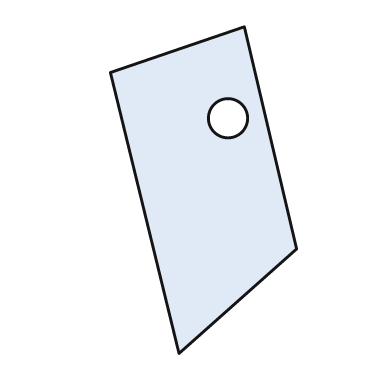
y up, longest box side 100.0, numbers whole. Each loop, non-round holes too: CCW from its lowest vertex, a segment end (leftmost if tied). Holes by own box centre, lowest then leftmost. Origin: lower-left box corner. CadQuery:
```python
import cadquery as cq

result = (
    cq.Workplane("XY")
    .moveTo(21.0, 0.0)
    .lineTo(57.0, 32.0)
    .lineTo(41.0, 100.0)
    .lineTo(0.0, 86.0)
    .close()
    .moveTo(36.0, 72.0)
    .circle(6.0)
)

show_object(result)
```